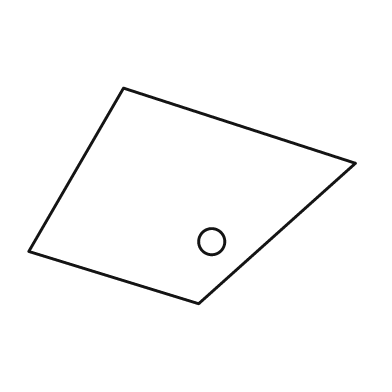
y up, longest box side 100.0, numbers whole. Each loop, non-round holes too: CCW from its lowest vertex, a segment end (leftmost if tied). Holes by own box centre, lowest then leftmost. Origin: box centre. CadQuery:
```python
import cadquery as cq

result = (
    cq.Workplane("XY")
    .moveTo(2.0, -33.0)
    .lineTo(50.0, 10.0)
    .lineTo(-21.0, 33.0)
    .lineTo(-50.0, -17.0)
    .close()
    .moveTo(6.0, -14.0)
    .circle(4.0)
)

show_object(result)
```